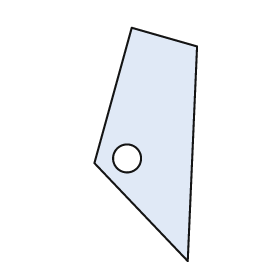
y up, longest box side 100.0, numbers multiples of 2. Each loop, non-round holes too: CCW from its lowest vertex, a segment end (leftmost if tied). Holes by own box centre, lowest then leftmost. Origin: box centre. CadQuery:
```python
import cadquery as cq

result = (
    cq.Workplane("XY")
    .moveTo(18.0, -50.0)
    .lineTo(22.0, 42.0)
    .lineTo(-6.0, 50.0)
    .lineTo(-22.0, -8.0)
    .close()
    .moveTo(-8.0, -6.0)
    .circle(6.0)
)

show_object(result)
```